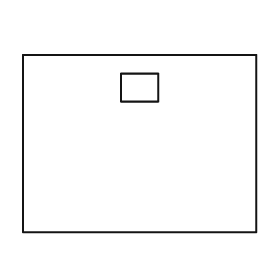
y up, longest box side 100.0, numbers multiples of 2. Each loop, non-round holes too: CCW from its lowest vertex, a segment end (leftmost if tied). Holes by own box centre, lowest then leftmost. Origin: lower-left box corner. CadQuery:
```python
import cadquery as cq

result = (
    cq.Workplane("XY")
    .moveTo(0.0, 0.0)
    .lineTo(100.0, 0.0)
    .lineTo(100.0, 76.0)
    .lineTo(0.0, 76.0)
    .close()
    .moveTo(42.0, 56.0)
    .lineTo(58.0, 56.0)
    .lineTo(58.0, 68.0)
    .lineTo(42.0, 68.0)
    .close()
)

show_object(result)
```